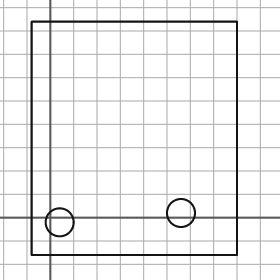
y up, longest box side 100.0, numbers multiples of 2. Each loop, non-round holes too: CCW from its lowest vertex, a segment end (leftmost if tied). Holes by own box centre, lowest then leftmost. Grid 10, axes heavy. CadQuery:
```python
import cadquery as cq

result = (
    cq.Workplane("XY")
    .moveTo(-8.0, -16.0)
    .lineTo(80.0, -16.0)
    .lineTo(80.0, 84.0)
    .lineTo(-8.0, 84.0)
    .close()
    .moveTo(4.0, -2.0)
    .circle(6.0)
    .moveTo(56.0, 2.0)
    .circle(6.0)
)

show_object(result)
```